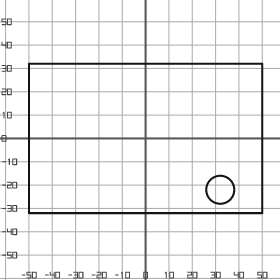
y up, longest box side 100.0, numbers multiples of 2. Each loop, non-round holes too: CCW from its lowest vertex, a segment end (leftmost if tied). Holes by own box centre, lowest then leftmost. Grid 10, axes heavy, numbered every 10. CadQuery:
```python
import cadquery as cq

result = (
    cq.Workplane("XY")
    .moveTo(-50.0, -32.0)
    .lineTo(50.0, -32.0)
    .lineTo(50.0, 32.0)
    .lineTo(-50.0, 32.0)
    .close()
    .moveTo(32.0, -22.0)
    .circle(6.0)
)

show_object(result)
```